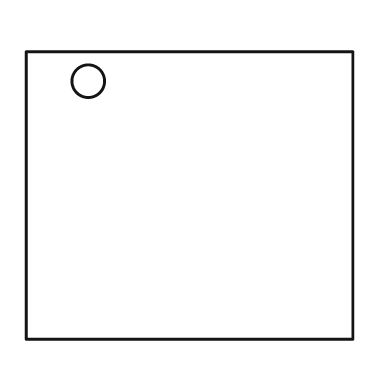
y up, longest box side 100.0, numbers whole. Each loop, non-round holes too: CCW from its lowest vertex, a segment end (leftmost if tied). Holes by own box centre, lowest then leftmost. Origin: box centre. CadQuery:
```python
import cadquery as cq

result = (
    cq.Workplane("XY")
    .moveTo(-50.0, -44.0)
    .lineTo(50.0, -44.0)
    .lineTo(50.0, 44.0)
    .lineTo(-50.0, 44.0)
    .close()
    .moveTo(-31.0, 35.0)
    .circle(5.0)
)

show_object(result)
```